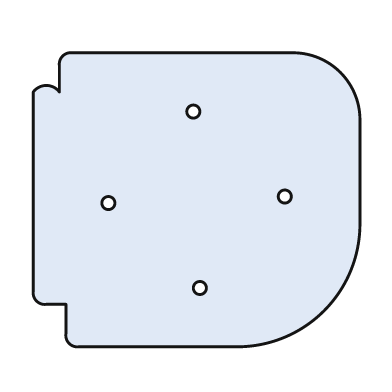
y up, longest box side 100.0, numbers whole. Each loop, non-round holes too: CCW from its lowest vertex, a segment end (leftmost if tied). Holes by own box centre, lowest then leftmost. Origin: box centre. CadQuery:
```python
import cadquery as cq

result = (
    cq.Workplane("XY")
    .moveTo(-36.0, -45.0)
    .lineTo(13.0, -45.0)
    .threePointArc((39.0, -34.0), (50.0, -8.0))
    .lineTo(50.0, 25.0)
    .threePointArc((44.0, 39.0), (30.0, 45.0))
    .lineTo(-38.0, 45.0)
    .threePointArc((-41.0, 44.0), (-42.0, 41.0))
    .lineTo(-42.0, 33.0)
    .threePointArc((-46.0, 35.0), (-50.0, 33.0))
    .lineTo(-50.0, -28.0)
    .threePointArc((-49.0, -31.0), (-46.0, -32.0))
    .lineTo(-40.0, -32.0)
    .lineTo(-40.0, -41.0)
    .threePointArc((-39.0, -44.0), (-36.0, -45.0))
    .close()
    .moveTo(1.0, -27.0)
    .circle(2.0)
    .moveTo(-27.0, -1.0)
    .circle(2.0)
    .moveTo(27.0, 1.0)
    .circle(2.0)
    .moveTo(-1.0, 27.0)
    .circle(2.0)
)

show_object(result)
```